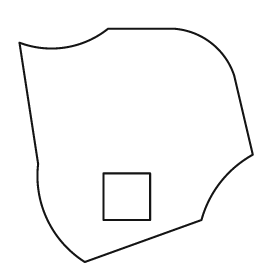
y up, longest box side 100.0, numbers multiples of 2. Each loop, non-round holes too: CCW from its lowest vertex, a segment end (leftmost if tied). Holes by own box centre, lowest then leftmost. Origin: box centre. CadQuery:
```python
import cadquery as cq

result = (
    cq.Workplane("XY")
    .moveTo(-22.0, -50.0)
    .lineTo(28.0, -32.0)
    .threePointArc((36.0, -16.0), (50.0, -4.0))
    .lineTo(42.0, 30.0)
    .threePointArc((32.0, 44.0), (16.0, 50.0))
    .lineTo(-12.0, 50.0)
    .threePointArc((-30.0, 42.0), (-50.0, 44.0))
    .lineTo(-42.0, -8.0)
    .threePointArc((-38.0, -32.0), (-22.0, -50.0))
    .close()
    .moveTo(-14.0, -32.0)
    .lineTo(6.0, -32.0)
    .lineTo(6.0, -12.0)
    .lineTo(-14.0, -12.0)
    .close()
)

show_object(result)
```